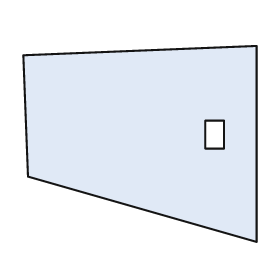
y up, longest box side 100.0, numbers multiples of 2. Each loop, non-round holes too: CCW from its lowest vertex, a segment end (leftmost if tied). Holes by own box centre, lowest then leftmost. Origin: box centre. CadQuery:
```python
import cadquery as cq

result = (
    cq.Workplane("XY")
    .moveTo(50.0, -42.0)
    .lineTo(50.0, 42.0)
    .lineTo(-50.0, 38.0)
    .lineTo(-48.0, -14.0)
    .close()
    .moveTo(28.0, -2.0)
    .lineTo(36.0, -2.0)
    .lineTo(36.0, 10.0)
    .lineTo(28.0, 10.0)
    .close()
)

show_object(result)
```